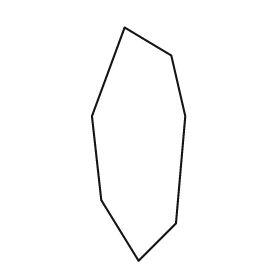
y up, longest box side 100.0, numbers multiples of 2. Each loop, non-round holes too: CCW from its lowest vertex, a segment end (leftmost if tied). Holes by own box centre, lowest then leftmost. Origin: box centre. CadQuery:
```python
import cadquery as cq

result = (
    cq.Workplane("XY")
    .moveTo(0.0, -50.0)
    .lineTo(16.0, -34.0)
    .lineTo(20.0, 12.0)
    .lineTo(14.0, 38.0)
    .lineTo(-6.0, 50.0)
    .lineTo(-20.0, 12.0)
    .lineTo(-16.0, -24.0)
    .close()
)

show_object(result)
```